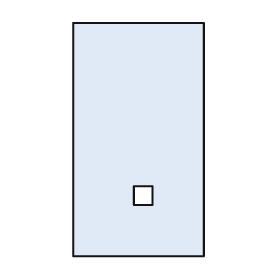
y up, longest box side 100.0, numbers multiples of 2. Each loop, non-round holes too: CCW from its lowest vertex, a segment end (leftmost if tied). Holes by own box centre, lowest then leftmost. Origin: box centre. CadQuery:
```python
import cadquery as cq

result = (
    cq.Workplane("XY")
    .moveTo(-28.0, -50.0)
    .lineTo(28.0, -50.0)
    .lineTo(28.0, 50.0)
    .lineTo(-28.0, 50.0)
    .close()
    .moveTo(-2.0, -28.0)
    .lineTo(6.0, -28.0)
    .lineTo(6.0, -20.0)
    .lineTo(-2.0, -20.0)
    .close()
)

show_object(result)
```